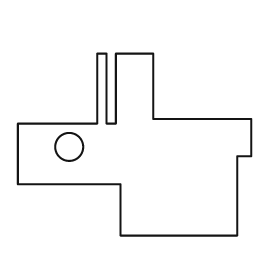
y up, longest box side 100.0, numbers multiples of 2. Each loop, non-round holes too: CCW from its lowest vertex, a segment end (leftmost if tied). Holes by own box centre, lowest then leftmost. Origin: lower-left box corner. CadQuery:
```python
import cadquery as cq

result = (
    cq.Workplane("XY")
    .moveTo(44.0, 0.0)
    .lineTo(94.0, 0.0)
    .lineTo(94.0, 34.0)
    .lineTo(100.0, 34.0)
    .lineTo(100.0, 50.0)
    .lineTo(58.0, 50.0)
    .lineTo(58.0, 78.0)
    .lineTo(42.0, 78.0)
    .lineTo(42.0, 48.0)
    .lineTo(38.0, 48.0)
    .lineTo(38.0, 78.0)
    .lineTo(34.0, 78.0)
    .lineTo(34.0, 48.0)
    .lineTo(0.0, 48.0)
    .lineTo(0.0, 22.0)
    .lineTo(44.0, 22.0)
    .close()
    .moveTo(22.0, 38.0)
    .circle(6.0)
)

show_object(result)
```